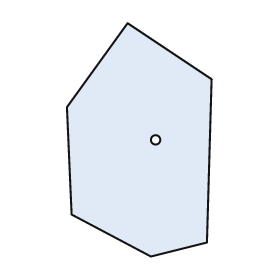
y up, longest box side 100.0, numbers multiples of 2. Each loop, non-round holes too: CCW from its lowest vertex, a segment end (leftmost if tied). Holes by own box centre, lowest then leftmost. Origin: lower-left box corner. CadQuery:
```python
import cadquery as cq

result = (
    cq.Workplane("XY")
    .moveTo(36.0, 0.0)
    .lineTo(60.0, 6.0)
    .lineTo(62.0, 76.0)
    .lineTo(26.0, 100.0)
    .lineTo(0.0, 64.0)
    .lineTo(2.0, 18.0)
    .close()
    .moveTo(38.0, 50.0)
    .circle(2.0)
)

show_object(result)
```